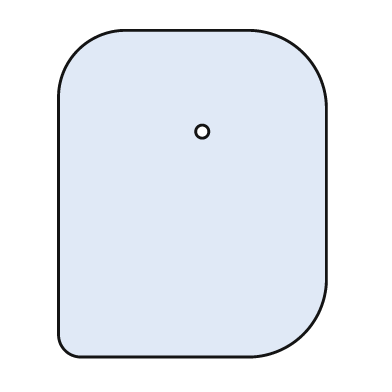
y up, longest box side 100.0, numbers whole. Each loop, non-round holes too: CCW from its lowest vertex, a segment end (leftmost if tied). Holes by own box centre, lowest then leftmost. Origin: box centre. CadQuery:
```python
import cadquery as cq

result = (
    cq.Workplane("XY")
    .moveTo(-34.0, -50.0)
    .lineTo(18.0, -50.0)
    .threePointArc((34.0, -43.0), (41.0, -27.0))
    .lineTo(41.0, 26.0)
    .threePointArc((34.0, 43.0), (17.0, 50.0))
    .lineTo(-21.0, 50.0)
    .threePointArc((-35.0, 44.0), (-41.0, 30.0))
    .lineTo(-41.0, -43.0)
    .threePointArc((-39.0, -48.0), (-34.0, -50.0))
    .close()
    .moveTo(3.0, 19.0)
    .circle(2.0)
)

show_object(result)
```